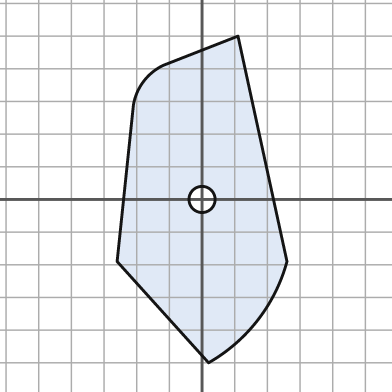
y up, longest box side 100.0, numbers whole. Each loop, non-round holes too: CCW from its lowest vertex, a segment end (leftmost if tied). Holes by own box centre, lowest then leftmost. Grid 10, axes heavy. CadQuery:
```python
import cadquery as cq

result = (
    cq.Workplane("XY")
    .moveTo(2.0, -50.0)
    .threePointArc((17.0, -37.0), (26.0, -19.0))
    .lineTo(11.0, 50.0)
    .lineTo(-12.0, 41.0)
    .threePointArc((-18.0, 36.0), (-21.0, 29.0))
    .lineTo(-26.0, -19.0)
    .close()
    .moveTo(0.0, 0.0)
    .circle(4.0)
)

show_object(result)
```